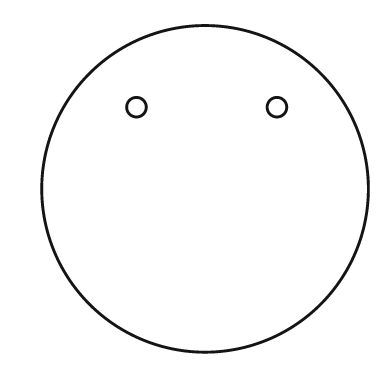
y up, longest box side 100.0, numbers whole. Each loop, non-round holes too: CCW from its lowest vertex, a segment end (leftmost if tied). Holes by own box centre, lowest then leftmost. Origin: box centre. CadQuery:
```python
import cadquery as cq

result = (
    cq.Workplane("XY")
    .moveTo(0.0, 0.0)
    .circle(50.0)
    .moveTo(-21.0, 25.0)
    .circle(3.0)
    .moveTo(22.0, 25.0)
    .circle(3.0)
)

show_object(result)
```